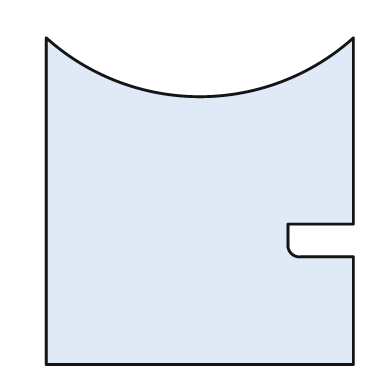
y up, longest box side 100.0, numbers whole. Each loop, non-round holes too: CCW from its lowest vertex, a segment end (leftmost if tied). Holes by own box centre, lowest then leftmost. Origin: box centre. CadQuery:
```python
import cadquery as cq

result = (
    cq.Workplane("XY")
    .moveTo(-47.0, -50.0)
    .lineTo(47.0, -50.0)
    .lineTo(47.0, -17.0)
    .lineTo(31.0, -17.0)
    .threePointArc((28.0, -16.0), (27.0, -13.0))
    .lineTo(27.0, -7.0)
    .lineTo(47.0, -7.0)
    .lineTo(47.0, 50.0)
    .threePointArc((0.0, 32.0), (-47.0, 50.0))
    .close()
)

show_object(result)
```